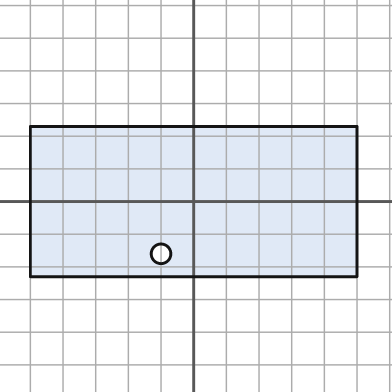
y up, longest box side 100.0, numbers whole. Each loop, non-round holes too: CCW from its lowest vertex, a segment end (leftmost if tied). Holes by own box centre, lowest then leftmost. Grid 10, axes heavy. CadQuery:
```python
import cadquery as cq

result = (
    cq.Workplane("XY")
    .moveTo(-50.0, -23.0)
    .lineTo(50.0, -23.0)
    .lineTo(50.0, 23.0)
    .lineTo(-50.0, 23.0)
    .close()
    .moveTo(-10.0, -16.0)
    .circle(3.0)
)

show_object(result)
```